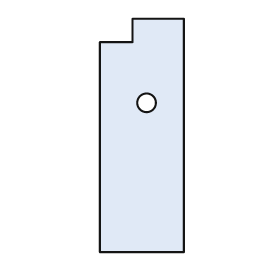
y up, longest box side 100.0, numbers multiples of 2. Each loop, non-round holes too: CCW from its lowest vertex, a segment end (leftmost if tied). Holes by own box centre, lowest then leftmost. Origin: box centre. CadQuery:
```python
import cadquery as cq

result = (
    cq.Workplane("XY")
    .moveTo(-18.0, -50.0)
    .lineTo(18.0, -50.0)
    .lineTo(18.0, 50.0)
    .lineTo(-4.0, 50.0)
    .lineTo(-4.0, 40.0)
    .lineTo(-18.0, 40.0)
    .close()
    .moveTo(2.0, 14.0)
    .circle(4.0)
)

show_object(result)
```